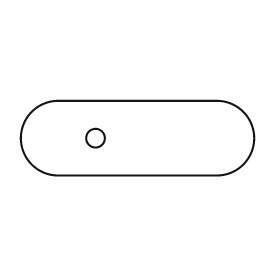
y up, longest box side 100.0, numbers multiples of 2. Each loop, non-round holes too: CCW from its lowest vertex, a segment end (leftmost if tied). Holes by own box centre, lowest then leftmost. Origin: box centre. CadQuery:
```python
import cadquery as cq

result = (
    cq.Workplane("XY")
    .moveTo(-34.0, -16.0)
    .lineTo(34.0, -16.0)
    .threePointArc((50.0, 0.0), (34.0, 16.0))
    .lineTo(-34.0, 16.0)
    .threePointArc((-50.0, 0.0), (-34.0, -16.0))
    .close()
    .moveTo(-18.0, 0.0)
    .circle(4.0)
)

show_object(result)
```